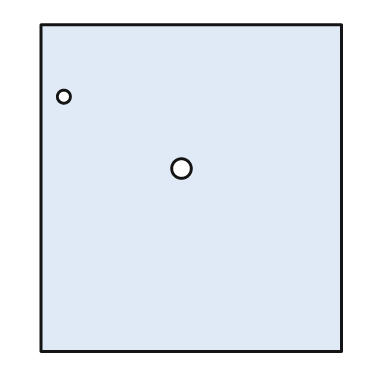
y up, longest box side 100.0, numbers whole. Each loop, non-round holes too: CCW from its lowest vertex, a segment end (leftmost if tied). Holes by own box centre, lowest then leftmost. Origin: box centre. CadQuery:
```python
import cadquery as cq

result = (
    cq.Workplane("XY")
    .moveTo(-46.0, -50.0)
    .lineTo(46.0, -50.0)
    .lineTo(46.0, 50.0)
    .lineTo(-46.0, 50.0)
    .close()
    .moveTo(-3.0, 6.0)
    .circle(3.0)
    .moveTo(-39.0, 28.0)
    .circle(2.0)
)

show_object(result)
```